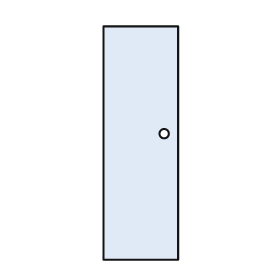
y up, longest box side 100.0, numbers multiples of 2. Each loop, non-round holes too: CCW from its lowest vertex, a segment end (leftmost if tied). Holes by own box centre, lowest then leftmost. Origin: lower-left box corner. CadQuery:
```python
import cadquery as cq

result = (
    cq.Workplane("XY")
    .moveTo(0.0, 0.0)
    .lineTo(32.0, 0.0)
    .lineTo(32.0, 100.0)
    .lineTo(0.0, 100.0)
    .close()
    .moveTo(26.0, 54.0)
    .circle(2.0)
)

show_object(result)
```